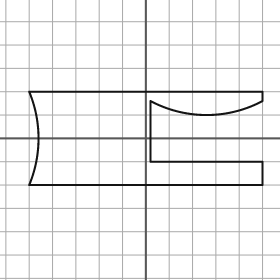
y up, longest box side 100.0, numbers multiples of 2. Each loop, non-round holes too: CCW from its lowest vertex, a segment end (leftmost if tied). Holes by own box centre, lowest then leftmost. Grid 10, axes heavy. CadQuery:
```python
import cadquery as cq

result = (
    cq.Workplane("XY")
    .moveTo(-50.0, -20.0)
    .lineTo(50.0, -20.0)
    .lineTo(50.0, -10.0)
    .lineTo(2.0, -10.0)
    .lineTo(2.0, 16.0)
    .threePointArc((26.0, 10.0), (50.0, 16.0))
    .lineTo(50.0, 20.0)
    .lineTo(-50.0, 20.0)
    .threePointArc((-46.0, 0.0), (-50.0, -20.0))
    .close()
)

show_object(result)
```